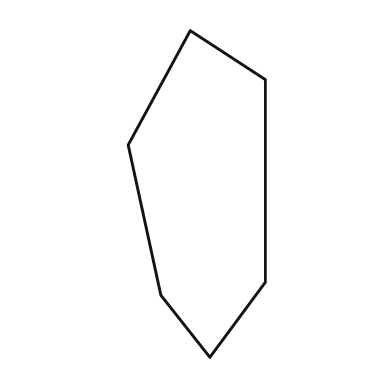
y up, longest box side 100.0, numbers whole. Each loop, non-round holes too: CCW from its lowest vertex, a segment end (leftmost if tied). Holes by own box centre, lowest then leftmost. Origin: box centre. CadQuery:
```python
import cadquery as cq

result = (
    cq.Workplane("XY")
    .moveTo(4.0, -50.0)
    .lineTo(21.0, -27.0)
    .lineTo(21.0, 35.0)
    .lineTo(-2.0, 50.0)
    .lineTo(-21.0, 15.0)
    .lineTo(-11.0, -31.0)
    .close()
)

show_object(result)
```